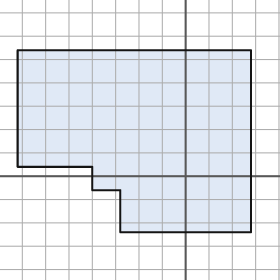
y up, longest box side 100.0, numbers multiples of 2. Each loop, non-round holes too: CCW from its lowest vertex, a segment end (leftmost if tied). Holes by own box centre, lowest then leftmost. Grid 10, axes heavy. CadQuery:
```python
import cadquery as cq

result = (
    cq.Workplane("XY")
    .moveTo(-28.0, -24.0)
    .lineTo(28.0, -24.0)
    .lineTo(28.0, 54.0)
    .lineTo(-72.0, 54.0)
    .lineTo(-72.0, 4.0)
    .lineTo(-40.0, 4.0)
    .lineTo(-40.0, -6.0)
    .lineTo(-28.0, -6.0)
    .close()
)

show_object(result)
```